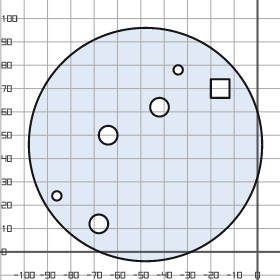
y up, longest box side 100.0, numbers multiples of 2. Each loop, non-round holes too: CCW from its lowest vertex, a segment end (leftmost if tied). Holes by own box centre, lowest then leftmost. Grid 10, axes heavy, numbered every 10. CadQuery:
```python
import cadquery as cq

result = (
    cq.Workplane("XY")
    .moveTo(-48.0, 46.0)
    .circle(50.0)
    .moveTo(-68.0, 12.0)
    .circle(4.0)
    .moveTo(-86.0, 24.0)
    .circle(2.0)
    .moveTo(-64.0, 50.0)
    .circle(4.0)
    .moveTo(-42.0, 62.0)
    .circle(4.0)
    .moveTo(-20.0, 66.0)
    .lineTo(-12.0, 66.0)
    .lineTo(-12.0, 74.0)
    .lineTo(-20.0, 74.0)
    .close()
    .moveTo(-34.0, 78.0)
    .circle(2.0)
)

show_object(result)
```